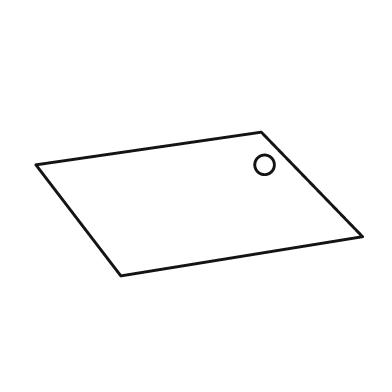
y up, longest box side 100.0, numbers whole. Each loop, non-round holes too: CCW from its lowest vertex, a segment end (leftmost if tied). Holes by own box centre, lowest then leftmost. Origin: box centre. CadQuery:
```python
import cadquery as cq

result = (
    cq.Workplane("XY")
    .moveTo(-24.0, -22.0)
    .lineTo(50.0, -10.0)
    .lineTo(19.0, 22.0)
    .lineTo(-50.0, 12.0)
    .close()
    .moveTo(20.0, 12.0)
    .circle(3.0)
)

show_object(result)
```